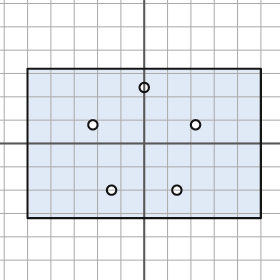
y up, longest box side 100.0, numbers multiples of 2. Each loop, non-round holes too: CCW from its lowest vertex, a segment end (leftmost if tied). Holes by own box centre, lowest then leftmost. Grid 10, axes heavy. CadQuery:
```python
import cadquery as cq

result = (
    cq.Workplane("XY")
    .moveTo(-50.0, -32.0)
    .lineTo(50.0, -32.0)
    .lineTo(50.0, 32.0)
    .lineTo(-50.0, 32.0)
    .close()
    .moveTo(-14.0, -20.0)
    .circle(2.0)
    .moveTo(14.0, -20.0)
    .circle(2.0)
    .moveTo(-22.0, 8.0)
    .circle(2.0)
    .moveTo(22.0, 8.0)
    .circle(2.0)
    .moveTo(0.0, 24.0)
    .circle(2.0)
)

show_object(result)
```